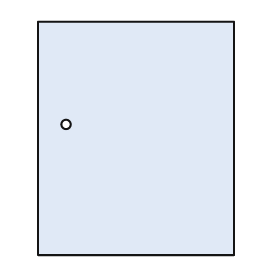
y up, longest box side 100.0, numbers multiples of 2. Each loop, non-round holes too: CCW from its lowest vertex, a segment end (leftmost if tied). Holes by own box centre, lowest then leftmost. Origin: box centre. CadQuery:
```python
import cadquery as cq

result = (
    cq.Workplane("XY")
    .moveTo(-42.0, -50.0)
    .lineTo(42.0, -50.0)
    .lineTo(42.0, 50.0)
    .lineTo(-42.0, 50.0)
    .close()
    .moveTo(-30.0, 6.0)
    .circle(2.0)
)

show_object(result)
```